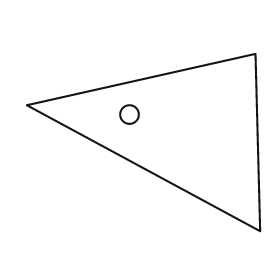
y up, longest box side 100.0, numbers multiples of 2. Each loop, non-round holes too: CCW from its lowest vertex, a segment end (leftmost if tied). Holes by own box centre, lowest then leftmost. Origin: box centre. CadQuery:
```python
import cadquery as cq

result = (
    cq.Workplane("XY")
    .moveTo(50.0, -38.0)
    .lineTo(48.0, 38.0)
    .lineTo(-50.0, 16.0)
    .close()
    .moveTo(-6.0, 12.0)
    .circle(4.0)
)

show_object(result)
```